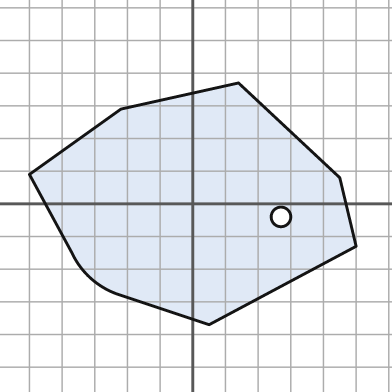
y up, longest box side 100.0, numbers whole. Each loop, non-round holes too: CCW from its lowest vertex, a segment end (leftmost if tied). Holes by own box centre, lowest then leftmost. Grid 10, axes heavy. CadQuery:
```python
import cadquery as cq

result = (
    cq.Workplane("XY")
    .moveTo(5.0, -37.0)
    .lineTo(50.0, -13.0)
    .lineTo(45.0, 8.0)
    .lineTo(14.0, 37.0)
    .lineTo(-22.0, 29.0)
    .lineTo(-50.0, 9.0)
    .lineTo(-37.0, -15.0)
    .threePointArc((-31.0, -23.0), (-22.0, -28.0))
    .close()
    .moveTo(27.0, -4.0)
    .circle(3.0)
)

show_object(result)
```